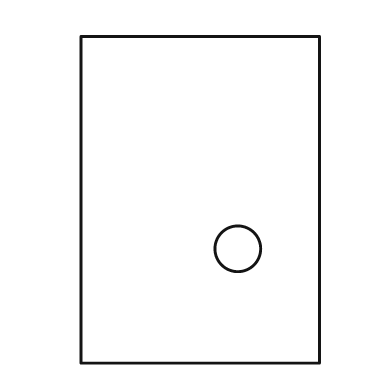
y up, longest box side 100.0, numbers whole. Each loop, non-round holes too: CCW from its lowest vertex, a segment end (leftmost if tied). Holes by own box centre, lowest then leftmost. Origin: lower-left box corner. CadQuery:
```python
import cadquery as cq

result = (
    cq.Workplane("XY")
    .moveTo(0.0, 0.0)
    .lineTo(73.0, 0.0)
    .lineTo(73.0, 100.0)
    .lineTo(0.0, 100.0)
    .close()
    .moveTo(48.0, 35.0)
    .circle(7.0)
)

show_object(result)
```